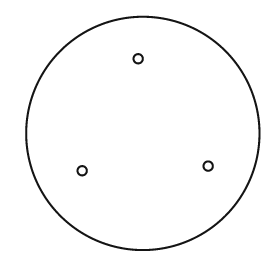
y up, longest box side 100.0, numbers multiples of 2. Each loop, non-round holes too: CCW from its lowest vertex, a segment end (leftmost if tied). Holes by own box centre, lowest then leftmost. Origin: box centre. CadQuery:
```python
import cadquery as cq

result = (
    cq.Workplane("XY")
    .moveTo(0.0, 0.0)
    .circle(50.0)
    .moveTo(-26.0, -16.0)
    .circle(2.0)
    .moveTo(28.0, -14.0)
    .circle(2.0)
    .moveTo(-2.0, 32.0)
    .circle(2.0)
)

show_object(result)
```